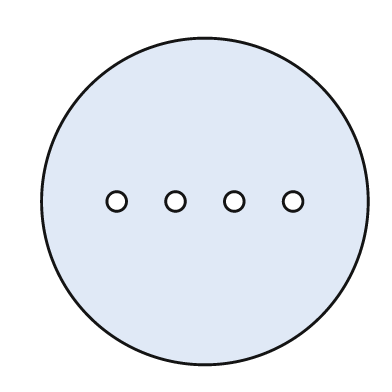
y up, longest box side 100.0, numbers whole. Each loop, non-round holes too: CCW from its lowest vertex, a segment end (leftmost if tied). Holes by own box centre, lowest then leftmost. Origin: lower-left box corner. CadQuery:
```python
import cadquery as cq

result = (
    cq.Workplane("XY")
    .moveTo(50.0, 50.0)
    .circle(50.0)
    .moveTo(23.0, 50.0)
    .circle(3.0)
    .moveTo(41.0, 50.0)
    .circle(3.0)
    .moveTo(59.0, 50.0)
    .circle(3.0)
    .moveTo(77.0, 50.0)
    .circle(3.0)
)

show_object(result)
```